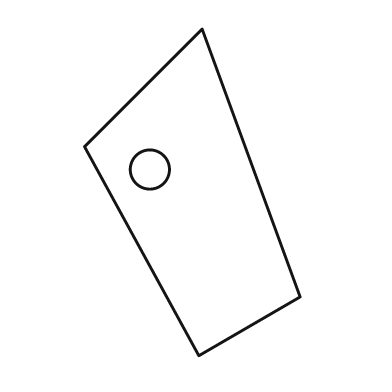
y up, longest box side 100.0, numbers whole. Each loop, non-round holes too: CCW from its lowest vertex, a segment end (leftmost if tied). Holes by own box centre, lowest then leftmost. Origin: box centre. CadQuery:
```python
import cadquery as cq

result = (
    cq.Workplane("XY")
    .moveTo(2.0, -50.0)
    .lineTo(33.0, -32.0)
    .lineTo(3.0, 50.0)
    .lineTo(-33.0, 14.0)
    .close()
    .moveTo(-13.0, 7.0)
    .circle(6.0)
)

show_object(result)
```